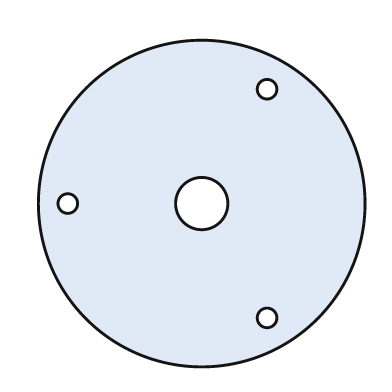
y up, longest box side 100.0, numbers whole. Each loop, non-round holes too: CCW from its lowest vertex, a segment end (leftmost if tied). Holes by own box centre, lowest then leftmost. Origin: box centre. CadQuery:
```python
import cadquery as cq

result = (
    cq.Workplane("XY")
    .moveTo(0.0, 0.0)
    .circle(50.0)
    .moveTo(20.0, -35.0)
    .circle(3.0)
    .moveTo(-41.0, 0.0)
    .circle(3.0)
    .moveTo(0.0, 0.0)
    .circle(8.0)
    .moveTo(20.0, 35.0)
    .circle(3.0)
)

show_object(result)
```